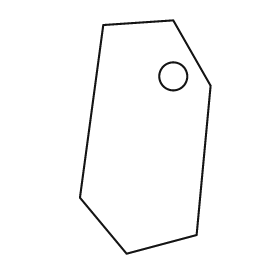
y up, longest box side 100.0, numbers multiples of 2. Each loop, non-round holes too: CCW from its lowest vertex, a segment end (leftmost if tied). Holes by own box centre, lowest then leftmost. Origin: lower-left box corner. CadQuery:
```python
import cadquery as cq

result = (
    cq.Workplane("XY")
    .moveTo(20.0, 0.0)
    .lineTo(50.0, 8.0)
    .lineTo(56.0, 72.0)
    .lineTo(40.0, 100.0)
    .lineTo(10.0, 98.0)
    .lineTo(0.0, 24.0)
    .close()
    .moveTo(40.0, 76.0)
    .circle(6.0)
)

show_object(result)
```